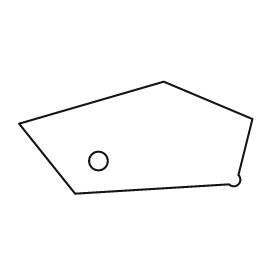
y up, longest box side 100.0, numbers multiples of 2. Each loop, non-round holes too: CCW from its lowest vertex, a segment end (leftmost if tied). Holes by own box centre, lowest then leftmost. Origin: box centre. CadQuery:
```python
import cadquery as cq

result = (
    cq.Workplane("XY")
    .moveTo(-26.0, -24.0)
    .lineTo(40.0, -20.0)
    .threePointArc((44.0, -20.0), (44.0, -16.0))
    .lineTo(50.0, 8.0)
    .lineTo(12.0, 24.0)
    .lineTo(-50.0, 6.0)
    .close()
    .moveTo(-16.0, -10.0)
    .circle(4.0)
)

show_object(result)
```